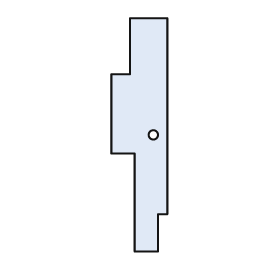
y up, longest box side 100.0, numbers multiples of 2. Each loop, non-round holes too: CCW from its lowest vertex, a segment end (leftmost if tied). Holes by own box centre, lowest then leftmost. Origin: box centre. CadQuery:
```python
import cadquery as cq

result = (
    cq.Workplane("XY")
    .moveTo(-2.0, -50.0)
    .lineTo(8.0, -50.0)
    .lineTo(8.0, -34.0)
    .lineTo(12.0, -34.0)
    .lineTo(12.0, 50.0)
    .lineTo(-4.0, 50.0)
    .lineTo(-4.0, 26.0)
    .lineTo(-12.0, 26.0)
    .lineTo(-12.0, -8.0)
    .lineTo(-2.0, -8.0)
    .close()
    .moveTo(6.0, 0.0)
    .circle(2.0)
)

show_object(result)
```